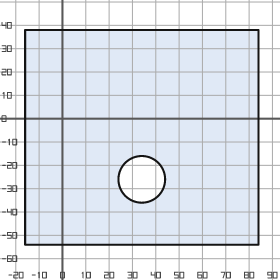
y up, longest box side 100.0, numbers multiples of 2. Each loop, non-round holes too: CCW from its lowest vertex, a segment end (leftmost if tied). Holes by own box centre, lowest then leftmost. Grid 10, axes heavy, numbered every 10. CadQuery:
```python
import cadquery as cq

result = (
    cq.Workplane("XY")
    .moveTo(-16.0, -54.0)
    .lineTo(84.0, -54.0)
    .lineTo(84.0, 38.0)
    .lineTo(-16.0, 38.0)
    .close()
    .moveTo(34.0, -26.0)
    .circle(10.0)
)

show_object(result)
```